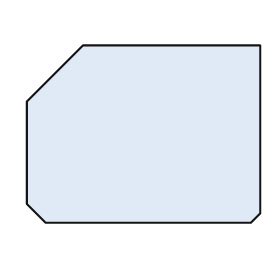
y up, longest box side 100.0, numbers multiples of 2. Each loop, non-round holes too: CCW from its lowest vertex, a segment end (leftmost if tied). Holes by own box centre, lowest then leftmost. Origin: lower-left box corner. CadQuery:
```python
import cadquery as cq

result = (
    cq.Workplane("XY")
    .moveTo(8.0, 0.0)
    .lineTo(96.0, 0.0)
    .lineTo(100.0, 4.0)
    .lineTo(100.0, 76.0)
    .lineTo(24.0, 76.0)
    .lineTo(0.0, 52.0)
    .lineTo(0.0, 8.0)
    .close()
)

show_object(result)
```